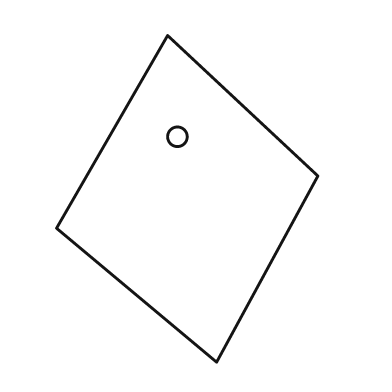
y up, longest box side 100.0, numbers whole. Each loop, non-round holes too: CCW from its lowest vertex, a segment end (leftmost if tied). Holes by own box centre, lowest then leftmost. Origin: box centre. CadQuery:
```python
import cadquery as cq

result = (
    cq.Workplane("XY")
    .moveTo(9.0, -50.0)
    .lineTo(40.0, 7.0)
    .lineTo(-6.0, 50.0)
    .lineTo(-40.0, -9.0)
    .close()
    .moveTo(-3.0, 19.0)
    .circle(3.0)
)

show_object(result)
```